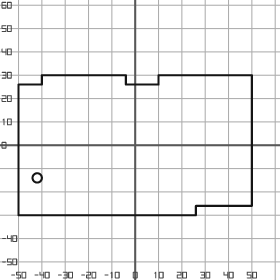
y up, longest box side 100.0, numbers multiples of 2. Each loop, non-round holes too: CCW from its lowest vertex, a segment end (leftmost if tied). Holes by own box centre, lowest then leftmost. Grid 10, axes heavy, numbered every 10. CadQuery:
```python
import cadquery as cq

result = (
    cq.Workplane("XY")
    .moveTo(-50.0, -30.0)
    .lineTo(26.0, -30.0)
    .lineTo(26.0, -26.0)
    .lineTo(50.0, -26.0)
    .lineTo(50.0, 30.0)
    .lineTo(10.0, 30.0)
    .lineTo(10.0, 26.0)
    .lineTo(-4.0, 26.0)
    .lineTo(-4.0, 30.0)
    .lineTo(-40.0, 30.0)
    .lineTo(-40.0, 26.0)
    .lineTo(-50.0, 26.0)
    .close()
    .moveTo(-42.0, -14.0)
    .circle(2.0)
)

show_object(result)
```